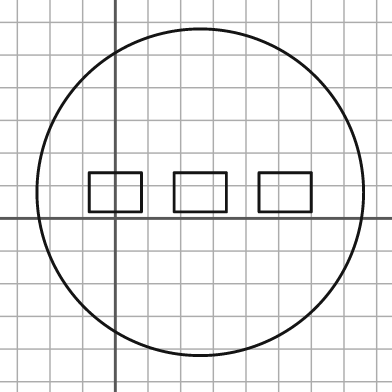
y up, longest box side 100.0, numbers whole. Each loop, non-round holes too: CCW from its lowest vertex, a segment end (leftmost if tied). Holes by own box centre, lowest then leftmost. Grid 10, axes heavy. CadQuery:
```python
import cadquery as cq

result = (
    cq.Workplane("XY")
    .moveTo(26.0, 8.0)
    .circle(50.0)
    .moveTo(-8.0, 2.0)
    .lineTo(8.0, 2.0)
    .lineTo(8.0, 14.0)
    .lineTo(-8.0, 14.0)
    .close()
    .moveTo(18.0, 2.0)
    .lineTo(34.0, 2.0)
    .lineTo(34.0, 14.0)
    .lineTo(18.0, 14.0)
    .close()
    .moveTo(44.0, 2.0)
    .lineTo(60.0, 2.0)
    .lineTo(60.0, 14.0)
    .lineTo(44.0, 14.0)
    .close()
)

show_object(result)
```